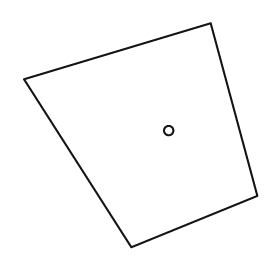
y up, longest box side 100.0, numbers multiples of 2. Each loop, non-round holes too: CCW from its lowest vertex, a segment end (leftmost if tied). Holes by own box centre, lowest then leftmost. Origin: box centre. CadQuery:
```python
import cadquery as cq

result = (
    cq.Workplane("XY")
    .moveTo(-4.0, -48.0)
    .lineTo(50.0, -26.0)
    .lineTo(30.0, 48.0)
    .lineTo(-50.0, 24.0)
    .close()
    .moveTo(12.0, 2.0)
    .circle(2.0)
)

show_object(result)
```